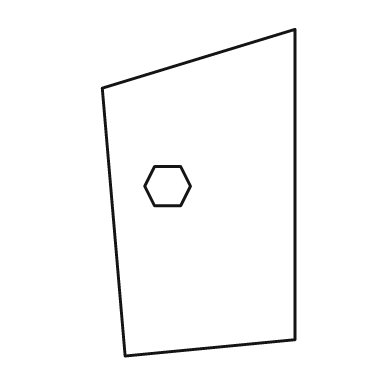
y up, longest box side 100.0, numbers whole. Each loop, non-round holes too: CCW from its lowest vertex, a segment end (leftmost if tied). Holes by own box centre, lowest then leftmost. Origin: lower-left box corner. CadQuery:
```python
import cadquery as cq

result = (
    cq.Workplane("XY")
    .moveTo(7.0, 0.0)
    .lineTo(59.0, 5.0)
    .lineTo(59.0, 100.0)
    .lineTo(0.0, 82.0)
    .close()
    .moveTo(16.0, 46.0)
    .lineTo(24.0, 46.0)
    .lineTo(27.0, 52.0)
    .lineTo(24.0, 58.0)
    .lineTo(16.0, 58.0)
    .lineTo(13.0, 52.0)
    .close()
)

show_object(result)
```